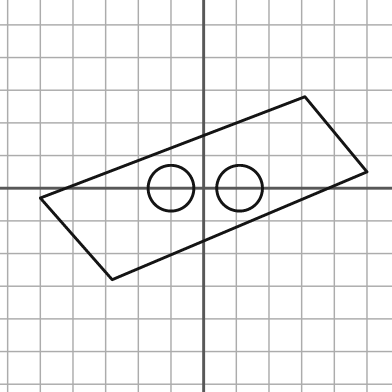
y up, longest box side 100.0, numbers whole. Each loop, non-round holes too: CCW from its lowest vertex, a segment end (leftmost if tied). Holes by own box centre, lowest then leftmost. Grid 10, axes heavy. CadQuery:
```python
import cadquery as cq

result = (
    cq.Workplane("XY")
    .moveTo(-28.0, -28.0)
    .lineTo(50.0, 5.0)
    .lineTo(31.0, 28.0)
    .lineTo(-50.0, -3.0)
    .close()
    .moveTo(-10.0, 0.0)
    .circle(7.0)
    .moveTo(11.0, 0.0)
    .circle(7.0)
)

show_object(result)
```